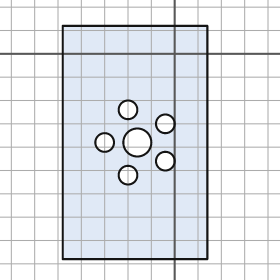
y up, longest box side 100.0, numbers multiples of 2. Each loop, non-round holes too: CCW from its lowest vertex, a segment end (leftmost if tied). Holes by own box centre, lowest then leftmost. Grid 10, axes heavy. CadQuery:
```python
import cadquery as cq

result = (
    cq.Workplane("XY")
    .moveTo(-48.0, -88.0)
    .lineTo(14.0, -88.0)
    .lineTo(14.0, 12.0)
    .lineTo(-48.0, 12.0)
    .close()
    .moveTo(-20.0, -52.0)
    .circle(4.0)
    .moveTo(-4.0, -46.0)
    .circle(4.0)
    .moveTo(-30.0, -38.0)
    .circle(4.0)
    .moveTo(-16.0, -38.0)
    .circle(6.0)
    .moveTo(-4.0, -30.0)
    .circle(4.0)
    .moveTo(-20.0, -24.0)
    .circle(4.0)
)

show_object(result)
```